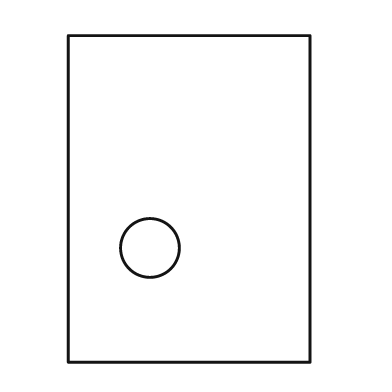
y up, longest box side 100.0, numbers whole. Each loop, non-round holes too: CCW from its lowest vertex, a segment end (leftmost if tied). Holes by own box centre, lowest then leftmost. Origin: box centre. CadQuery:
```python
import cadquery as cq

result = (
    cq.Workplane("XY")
    .moveTo(-37.0, -50.0)
    .lineTo(37.0, -50.0)
    .lineTo(37.0, 50.0)
    .lineTo(-37.0, 50.0)
    .close()
    .moveTo(-12.0, -15.0)
    .circle(9.0)
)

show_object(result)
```